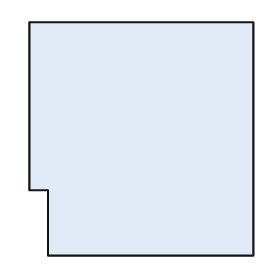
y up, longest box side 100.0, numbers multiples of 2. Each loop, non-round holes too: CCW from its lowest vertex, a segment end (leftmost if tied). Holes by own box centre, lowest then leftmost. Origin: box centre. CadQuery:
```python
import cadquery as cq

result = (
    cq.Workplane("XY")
    .moveTo(-40.0, -50.0)
    .lineTo(48.0, -50.0)
    .lineTo(48.0, 50.0)
    .lineTo(-48.0, 50.0)
    .lineTo(-48.0, -22.0)
    .lineTo(-40.0, -22.0)
    .close()
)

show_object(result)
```